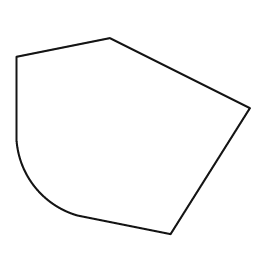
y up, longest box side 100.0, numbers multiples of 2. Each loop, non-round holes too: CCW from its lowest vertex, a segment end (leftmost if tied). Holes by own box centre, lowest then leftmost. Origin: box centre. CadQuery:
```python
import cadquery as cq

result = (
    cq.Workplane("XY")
    .moveTo(16.0, -42.0)
    .lineTo(50.0, 12.0)
    .lineTo(-10.0, 42.0)
    .lineTo(-50.0, 34.0)
    .lineTo(-50.0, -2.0)
    .threePointArc((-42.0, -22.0), (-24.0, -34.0))
    .close()
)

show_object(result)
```